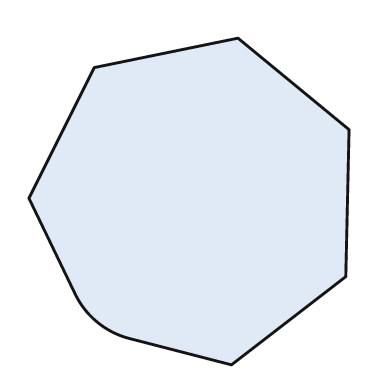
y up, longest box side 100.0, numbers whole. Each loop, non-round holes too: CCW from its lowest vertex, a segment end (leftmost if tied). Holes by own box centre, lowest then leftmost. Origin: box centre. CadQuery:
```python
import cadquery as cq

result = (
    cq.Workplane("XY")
    .moveTo(13.0, -50.0)
    .lineTo(48.0, -23.0)
    .lineTo(49.0, 22.0)
    .lineTo(15.0, 50.0)
    .lineTo(-29.0, 41.0)
    .lineTo(-49.0, 1.0)
    .lineTo(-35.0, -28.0)
    .threePointArc((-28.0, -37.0), (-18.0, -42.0))
    .close()
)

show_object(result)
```